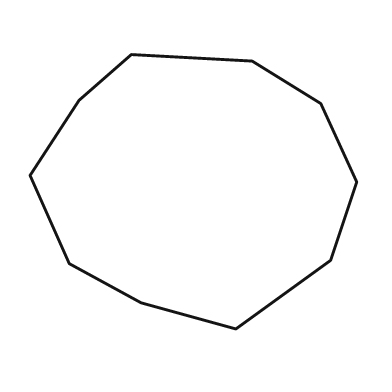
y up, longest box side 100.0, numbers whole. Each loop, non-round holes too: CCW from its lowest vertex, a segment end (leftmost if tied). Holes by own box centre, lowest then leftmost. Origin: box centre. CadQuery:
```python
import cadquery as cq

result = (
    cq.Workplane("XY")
    .moveTo(13.0, -42.0)
    .lineTo(42.0, -21.0)
    .lineTo(50.0, 3.0)
    .lineTo(39.0, 27.0)
    .lineTo(18.0, 40.0)
    .lineTo(-19.0, 42.0)
    .lineTo(-35.0, 28.0)
    .lineTo(-50.0, 5.0)
    .lineTo(-38.0, -22.0)
    .lineTo(-16.0, -34.0)
    .close()
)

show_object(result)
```